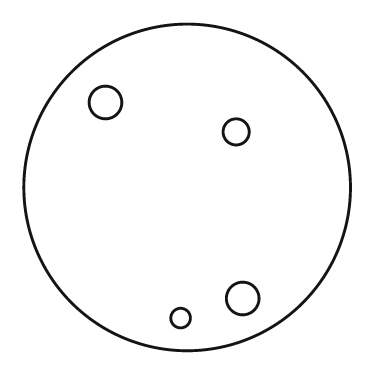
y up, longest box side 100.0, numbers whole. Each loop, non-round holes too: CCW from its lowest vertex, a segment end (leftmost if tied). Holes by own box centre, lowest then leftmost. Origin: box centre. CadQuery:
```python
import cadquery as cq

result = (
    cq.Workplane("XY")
    .moveTo(0.0, 0.0)
    .circle(50.0)
    .moveTo(-2.0, -40.0)
    .circle(3.0)
    .moveTo(17.0, -34.0)
    .circle(5.0)
    .moveTo(15.0, 17.0)
    .circle(4.0)
    .moveTo(-25.0, 26.0)
    .circle(5.0)
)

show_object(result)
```